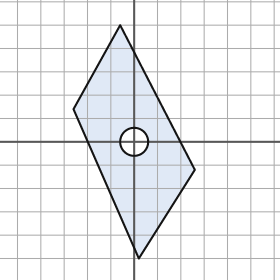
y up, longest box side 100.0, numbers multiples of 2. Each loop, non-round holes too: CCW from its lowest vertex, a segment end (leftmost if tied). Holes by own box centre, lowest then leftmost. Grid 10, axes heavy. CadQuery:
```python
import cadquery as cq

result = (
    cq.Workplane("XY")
    .moveTo(2.0, -50.0)
    .lineTo(26.0, -12.0)
    .lineTo(-6.0, 50.0)
    .lineTo(-26.0, 14.0)
    .close()
    .moveTo(0.0, 0.0)
    .circle(6.0)
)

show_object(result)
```